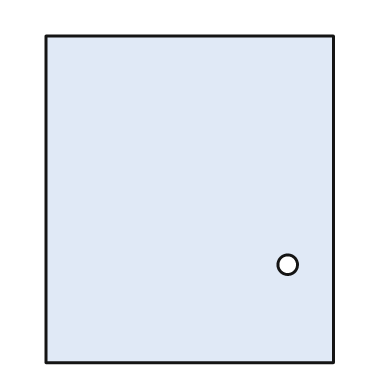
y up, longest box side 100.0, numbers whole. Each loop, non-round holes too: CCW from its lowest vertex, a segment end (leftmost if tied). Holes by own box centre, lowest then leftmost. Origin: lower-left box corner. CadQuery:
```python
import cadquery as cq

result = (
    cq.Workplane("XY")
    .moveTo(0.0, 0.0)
    .lineTo(88.0, 0.0)
    .lineTo(88.0, 100.0)
    .lineTo(0.0, 100.0)
    .close()
    .moveTo(74.0, 30.0)
    .circle(3.0)
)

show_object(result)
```